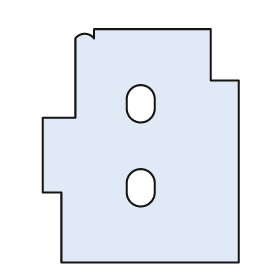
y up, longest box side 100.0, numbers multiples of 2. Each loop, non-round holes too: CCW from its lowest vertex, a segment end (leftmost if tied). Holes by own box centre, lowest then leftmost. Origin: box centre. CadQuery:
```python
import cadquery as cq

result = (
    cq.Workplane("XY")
    .moveTo(-34.0, -50.0)
    .lineTo(42.0, -50.0)
    .lineTo(42.0, 28.0)
    .lineTo(30.0, 28.0)
    .lineTo(30.0, 50.0)
    .lineTo(-20.0, 50.0)
    .lineTo(-20.0, 46.0)
    .threePointArc((-24.0, 48.0), (-28.0, 46.0))
    .lineTo(-28.0, 12.0)
    .lineTo(-42.0, 12.0)
    .lineTo(-42.0, -20.0)
    .lineTo(-34.0, -20.0)
    .close()
    .moveTo(-6.0, -20.0)
    .threePointArc((0.0, -26.0), (6.0, -20.0))
    .lineTo(6.0, -16.0)
    .threePointArc((0.0, -10.0), (-6.0, -16.0))
    .close()
    .moveTo(-6.0, 16.0)
    .threePointArc((0.0, 10.0), (6.0, 16.0))
    .lineTo(6.0, 20.0)
    .threePointArc((0.0, 26.0), (-6.0, 20.0))
    .close()
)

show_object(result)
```